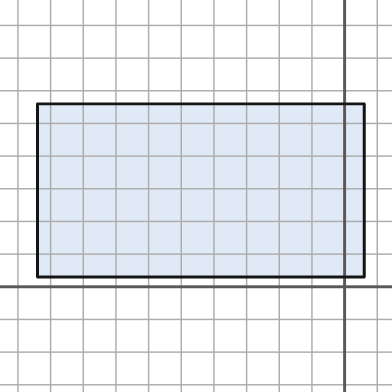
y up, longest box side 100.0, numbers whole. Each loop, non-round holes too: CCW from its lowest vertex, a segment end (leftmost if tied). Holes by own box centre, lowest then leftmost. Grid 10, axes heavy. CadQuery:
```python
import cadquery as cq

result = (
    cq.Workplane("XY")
    .moveTo(-94.0, 3.0)
    .lineTo(6.0, 3.0)
    .lineTo(6.0, 56.0)
    .lineTo(-94.0, 56.0)
    .close()
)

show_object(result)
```